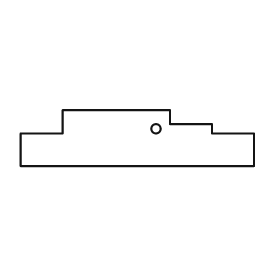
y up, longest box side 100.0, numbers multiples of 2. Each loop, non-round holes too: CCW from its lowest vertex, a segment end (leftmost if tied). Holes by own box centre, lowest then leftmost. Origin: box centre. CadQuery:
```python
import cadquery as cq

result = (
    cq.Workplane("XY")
    .moveTo(-50.0, -12.0)
    .lineTo(50.0, -12.0)
    .lineTo(50.0, 2.0)
    .lineTo(32.0, 2.0)
    .lineTo(32.0, 6.0)
    .lineTo(14.0, 6.0)
    .lineTo(14.0, 12.0)
    .lineTo(-32.0, 12.0)
    .lineTo(-32.0, 2.0)
    .lineTo(-50.0, 2.0)
    .close()
    .moveTo(8.0, 4.0)
    .circle(2.0)
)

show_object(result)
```